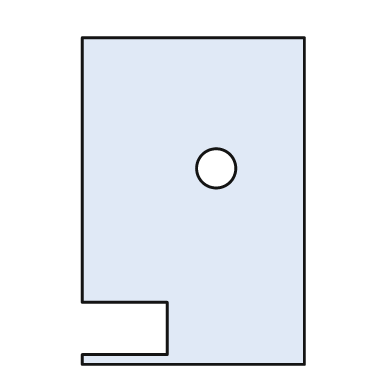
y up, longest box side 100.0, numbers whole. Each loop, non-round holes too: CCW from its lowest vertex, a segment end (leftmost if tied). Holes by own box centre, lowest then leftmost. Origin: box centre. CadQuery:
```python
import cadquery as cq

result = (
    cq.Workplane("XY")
    .moveTo(-34.0, -50.0)
    .lineTo(34.0, -50.0)
    .lineTo(34.0, 50.0)
    .lineTo(-34.0, 50.0)
    .lineTo(-34.0, -31.0)
    .lineTo(-8.0, -31.0)
    .lineTo(-8.0, -47.0)
    .lineTo(-34.0, -47.0)
    .close()
    .moveTo(7.0, 10.0)
    .circle(6.0)
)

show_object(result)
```